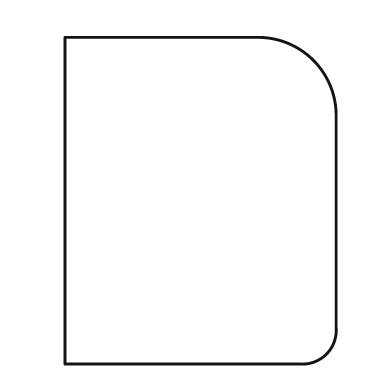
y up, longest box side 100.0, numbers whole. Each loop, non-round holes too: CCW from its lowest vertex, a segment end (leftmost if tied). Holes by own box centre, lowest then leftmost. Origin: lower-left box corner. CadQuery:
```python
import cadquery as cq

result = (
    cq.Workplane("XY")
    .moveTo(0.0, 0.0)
    .lineTo(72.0, 0.0)
    .threePointArc((80.0, 3.0), (83.0, 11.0))
    .lineTo(83.0, 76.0)
    .threePointArc((76.0, 93.0), (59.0, 100.0))
    .lineTo(0.0, 100.0)
    .close()
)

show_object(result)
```